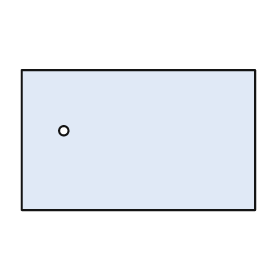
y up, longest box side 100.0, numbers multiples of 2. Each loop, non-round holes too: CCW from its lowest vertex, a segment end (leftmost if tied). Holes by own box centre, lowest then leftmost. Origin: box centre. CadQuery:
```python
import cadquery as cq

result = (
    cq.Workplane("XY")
    .moveTo(-50.0, -30.0)
    .lineTo(50.0, -30.0)
    .lineTo(50.0, 30.0)
    .lineTo(-50.0, 30.0)
    .close()
    .moveTo(-32.0, 4.0)
    .circle(2.0)
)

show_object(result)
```